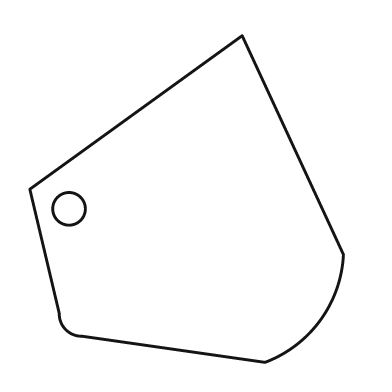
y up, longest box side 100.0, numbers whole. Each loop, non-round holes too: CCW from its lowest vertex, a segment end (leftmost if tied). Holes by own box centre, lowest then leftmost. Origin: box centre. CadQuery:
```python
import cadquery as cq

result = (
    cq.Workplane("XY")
    .moveTo(24.0, -50.0)
    .threePointArc((41.0, -37.0), (48.0, -17.0))
    .lineTo(17.0, 50.0)
    .lineTo(-48.0, 3.0)
    .lineTo(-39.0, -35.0)
    .threePointArc((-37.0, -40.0), (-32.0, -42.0))
    .close()
    .moveTo(-36.0, -3.0)
    .circle(5.0)
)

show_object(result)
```